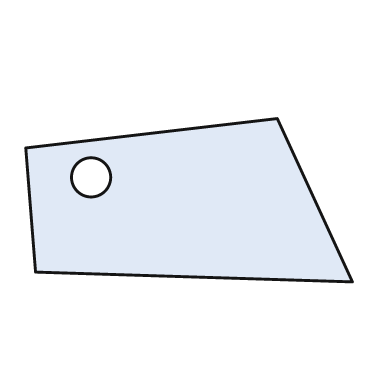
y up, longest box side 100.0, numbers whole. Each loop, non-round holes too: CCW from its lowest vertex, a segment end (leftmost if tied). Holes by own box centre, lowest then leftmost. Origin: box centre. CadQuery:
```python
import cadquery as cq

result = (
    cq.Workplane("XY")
    .moveTo(50.0, -25.0)
    .lineTo(27.0, 25.0)
    .lineTo(-50.0, 16.0)
    .lineTo(-47.0, -22.0)
    .close()
    .moveTo(-30.0, 7.0)
    .circle(6.0)
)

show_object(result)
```